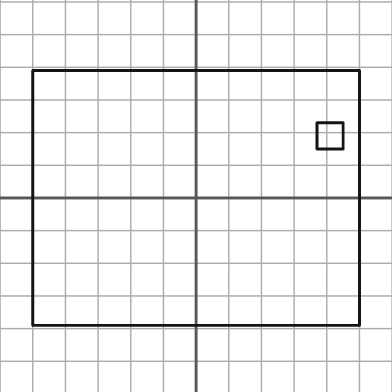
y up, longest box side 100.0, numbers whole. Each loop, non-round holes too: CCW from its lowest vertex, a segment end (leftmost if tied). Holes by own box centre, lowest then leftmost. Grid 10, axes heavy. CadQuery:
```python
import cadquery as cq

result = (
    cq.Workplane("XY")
    .moveTo(-50.0, -39.0)
    .lineTo(50.0, -39.0)
    .lineTo(50.0, 39.0)
    .lineTo(-50.0, 39.0)
    .close()
    .moveTo(37.0, 15.0)
    .lineTo(45.0, 15.0)
    .lineTo(45.0, 23.0)
    .lineTo(37.0, 23.0)
    .close()
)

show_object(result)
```